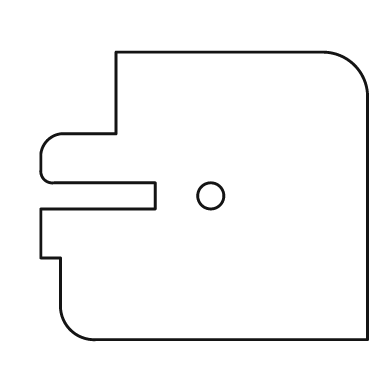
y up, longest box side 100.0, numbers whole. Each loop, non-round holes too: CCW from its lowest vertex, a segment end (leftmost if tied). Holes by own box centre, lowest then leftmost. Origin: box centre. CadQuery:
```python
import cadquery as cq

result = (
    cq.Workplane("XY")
    .moveTo(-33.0, -44.0)
    .lineTo(50.0, -44.0)
    .lineTo(50.0, 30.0)
    .threePointArc((46.0, 40.0), (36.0, 44.0))
    .lineTo(-27.0, 44.0)
    .lineTo(-27.0, 19.0)
    .lineTo(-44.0, 19.0)
    .threePointArc((-48.0, 17.0), (-50.0, 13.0))
    .lineTo(-50.0, 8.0)
    .threePointArc((-49.0, 5.0), (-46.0, 4.0))
    .lineTo(-15.0, 4.0)
    .lineTo(-15.0, -4.0)
    .lineTo(-50.0, -4.0)
    .lineTo(-50.0, -19.0)
    .lineTo(-44.0, -19.0)
    .lineTo(-44.0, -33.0)
    .threePointArc((-41.0, -41.0), (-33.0, -44.0))
    .close()
    .moveTo(2.0, 0.0)
    .circle(4.0)
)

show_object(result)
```